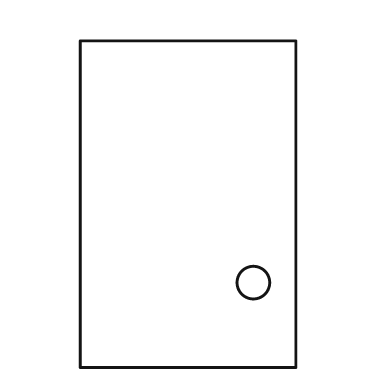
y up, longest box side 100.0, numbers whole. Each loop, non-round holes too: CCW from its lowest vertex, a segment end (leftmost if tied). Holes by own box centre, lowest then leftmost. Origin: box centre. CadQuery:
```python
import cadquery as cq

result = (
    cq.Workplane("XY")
    .moveTo(-33.0, -50.0)
    .lineTo(33.0, -50.0)
    .lineTo(33.0, 50.0)
    .lineTo(-33.0, 50.0)
    .close()
    .moveTo(20.0, -24.0)
    .circle(5.0)
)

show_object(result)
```